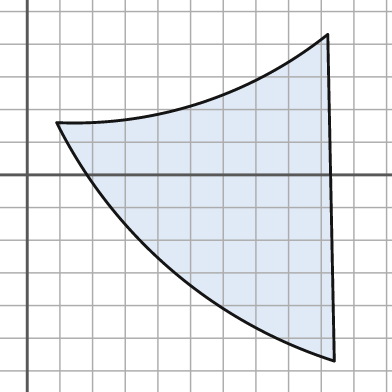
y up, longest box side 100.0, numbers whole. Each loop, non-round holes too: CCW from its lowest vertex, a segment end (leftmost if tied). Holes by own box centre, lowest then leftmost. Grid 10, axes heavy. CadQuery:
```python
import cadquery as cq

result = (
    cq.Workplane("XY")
    .moveTo(94.0, -57.0)
    .lineTo(92.0, 43.0)
    .threePointArc((53.0, 22.0), (9.0, 16.0))
    .threePointArc((44.0, -29.0), (94.0, -57.0))
    .close()
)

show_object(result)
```